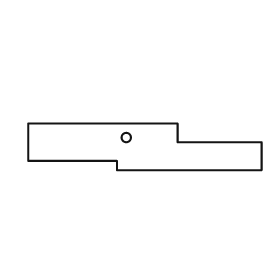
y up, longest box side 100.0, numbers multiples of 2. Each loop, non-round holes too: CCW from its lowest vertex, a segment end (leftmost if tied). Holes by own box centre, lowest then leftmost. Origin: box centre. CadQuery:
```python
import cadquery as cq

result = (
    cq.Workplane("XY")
    .moveTo(-12.0, -10.0)
    .lineTo(50.0, -10.0)
    .lineTo(50.0, 2.0)
    .lineTo(14.0, 2.0)
    .lineTo(14.0, 10.0)
    .lineTo(-50.0, 10.0)
    .lineTo(-50.0, -6.0)
    .lineTo(-12.0, -6.0)
    .close()
    .moveTo(-8.0, 4.0)
    .circle(2.0)
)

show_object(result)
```